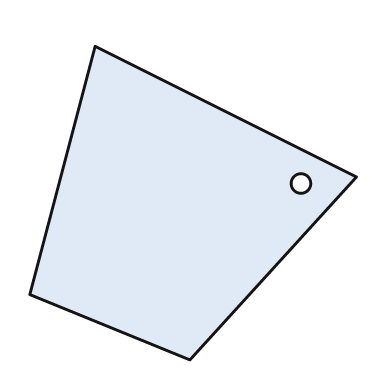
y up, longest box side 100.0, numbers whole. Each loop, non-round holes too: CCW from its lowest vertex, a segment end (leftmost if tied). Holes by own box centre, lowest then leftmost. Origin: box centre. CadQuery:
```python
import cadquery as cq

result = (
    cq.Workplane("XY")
    .moveTo(-1.0, -48.0)
    .lineTo(50.0, 8.0)
    .lineTo(-30.0, 48.0)
    .lineTo(-50.0, -28.0)
    .close()
    .moveTo(33.0, 6.0)
    .circle(3.0)
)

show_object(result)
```